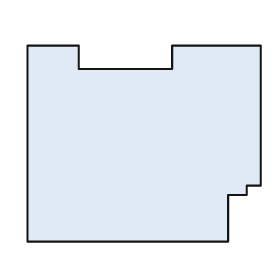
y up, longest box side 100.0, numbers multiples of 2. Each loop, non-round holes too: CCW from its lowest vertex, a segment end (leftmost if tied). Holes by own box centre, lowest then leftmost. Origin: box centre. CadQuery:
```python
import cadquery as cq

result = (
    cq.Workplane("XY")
    .moveTo(-50.0, -42.0)
    .lineTo(36.0, -42.0)
    .lineTo(36.0, -22.0)
    .lineTo(44.0, -22.0)
    .lineTo(44.0, -18.0)
    .lineTo(50.0, -18.0)
    .lineTo(50.0, 42.0)
    .lineTo(12.0, 42.0)
    .lineTo(12.0, 32.0)
    .lineTo(-28.0, 32.0)
    .lineTo(-28.0, 42.0)
    .lineTo(-50.0, 42.0)
    .close()
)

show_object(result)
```